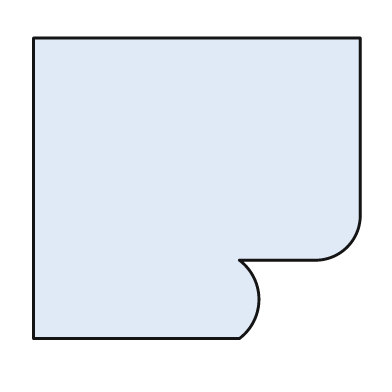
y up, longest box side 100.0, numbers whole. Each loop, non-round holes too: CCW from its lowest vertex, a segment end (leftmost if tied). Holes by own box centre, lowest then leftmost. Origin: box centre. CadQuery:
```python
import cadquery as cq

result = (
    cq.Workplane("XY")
    .moveTo(-50.0, -46.0)
    .lineTo(13.0, -46.0)
    .threePointArc((19.0, -34.0), (13.0, -22.0))
    .lineTo(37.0, -22.0)
    .threePointArc((46.0, -18.0), (50.0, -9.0))
    .lineTo(50.0, 46.0)
    .lineTo(-50.0, 46.0)
    .close()
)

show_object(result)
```